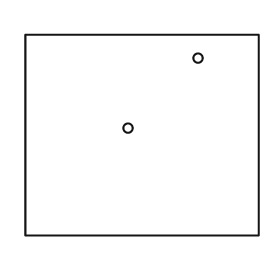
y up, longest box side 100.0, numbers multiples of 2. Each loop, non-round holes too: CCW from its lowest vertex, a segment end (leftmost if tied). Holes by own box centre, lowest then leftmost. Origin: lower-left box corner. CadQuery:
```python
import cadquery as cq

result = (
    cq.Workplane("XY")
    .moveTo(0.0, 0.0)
    .lineTo(100.0, 0.0)
    .lineTo(100.0, 86.0)
    .lineTo(0.0, 86.0)
    .close()
    .moveTo(44.0, 46.0)
    .circle(2.0)
    .moveTo(74.0, 76.0)
    .circle(2.0)
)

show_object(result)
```